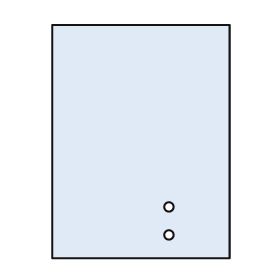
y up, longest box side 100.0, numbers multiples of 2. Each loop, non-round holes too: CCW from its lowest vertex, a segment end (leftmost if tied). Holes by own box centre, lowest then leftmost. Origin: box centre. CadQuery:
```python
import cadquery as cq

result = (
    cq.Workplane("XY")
    .moveTo(-38.0, -50.0)
    .lineTo(38.0, -50.0)
    .lineTo(38.0, 50.0)
    .lineTo(-38.0, 50.0)
    .close()
    .moveTo(12.0, -40.0)
    .circle(2.0)
    .moveTo(12.0, -28.0)
    .circle(2.0)
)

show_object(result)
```